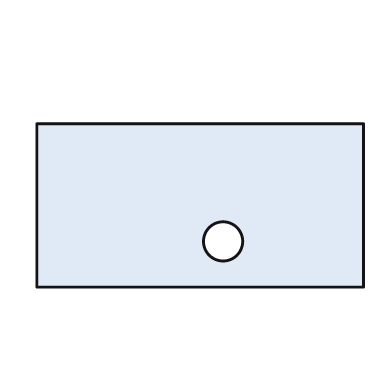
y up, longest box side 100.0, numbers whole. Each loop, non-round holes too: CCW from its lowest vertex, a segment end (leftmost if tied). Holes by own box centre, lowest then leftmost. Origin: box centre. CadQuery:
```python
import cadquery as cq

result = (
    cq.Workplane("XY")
    .moveTo(-50.0, -25.0)
    .lineTo(50.0, -25.0)
    .lineTo(50.0, 25.0)
    .lineTo(-50.0, 25.0)
    .close()
    .moveTo(7.0, -11.0)
    .circle(6.0)
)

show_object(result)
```